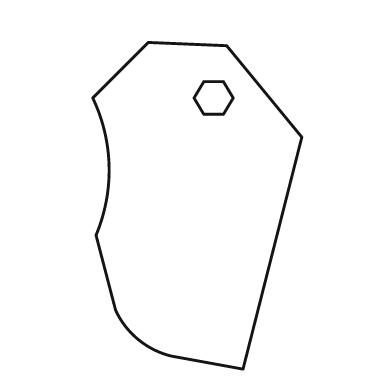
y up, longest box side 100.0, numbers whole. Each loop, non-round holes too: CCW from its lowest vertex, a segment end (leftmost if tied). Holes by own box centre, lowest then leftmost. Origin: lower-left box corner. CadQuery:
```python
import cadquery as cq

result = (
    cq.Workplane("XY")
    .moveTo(46.0, 0.0)
    .lineTo(64.0, 71.0)
    .lineTo(41.0, 99.0)
    .lineTo(17.0, 100.0)
    .lineTo(0.0, 83.0)
    .threePointArc((5.0, 62.0), (1.0, 41.0))
    .lineTo(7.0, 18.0)
    .threePointArc((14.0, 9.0), (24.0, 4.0))
    .close()
    .moveTo(34.0, 78.0)
    .lineTo(40.0, 78.0)
    .lineTo(43.0, 83.0)
    .lineTo(40.0, 88.0)
    .lineTo(34.0, 88.0)
    .lineTo(31.0, 83.0)
    .close()
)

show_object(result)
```